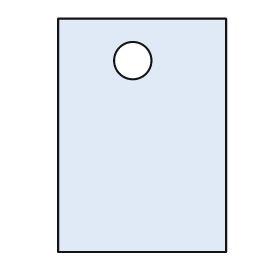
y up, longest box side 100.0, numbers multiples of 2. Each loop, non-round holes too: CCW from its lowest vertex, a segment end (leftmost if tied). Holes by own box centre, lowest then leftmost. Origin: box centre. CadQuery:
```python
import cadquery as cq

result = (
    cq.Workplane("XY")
    .moveTo(-36.0, -50.0)
    .lineTo(36.0, -50.0)
    .lineTo(36.0, 50.0)
    .lineTo(-36.0, 50.0)
    .close()
    .moveTo(-4.0, 32.0)
    .circle(8.0)
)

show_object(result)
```